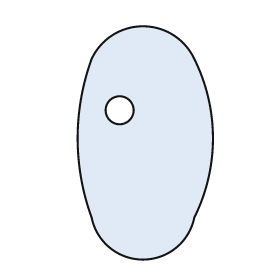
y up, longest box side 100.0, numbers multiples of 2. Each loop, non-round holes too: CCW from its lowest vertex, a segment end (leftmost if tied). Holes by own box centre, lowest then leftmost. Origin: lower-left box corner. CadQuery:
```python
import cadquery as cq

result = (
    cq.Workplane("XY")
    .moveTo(6.0, 18.0)
    .threePointArc((28.0, 0.0), (50.0, 18.0))
    .threePointArc((58.0, 52.0), (50.0, 86.0))
    .threePointArc((28.0, 100.0), (6.0, 86.0))
    .threePointArc((0.0, 52.0), (6.0, 18.0))
    .close()
    .moveTo(18.0, 64.0)
    .circle(6.0)
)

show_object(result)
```